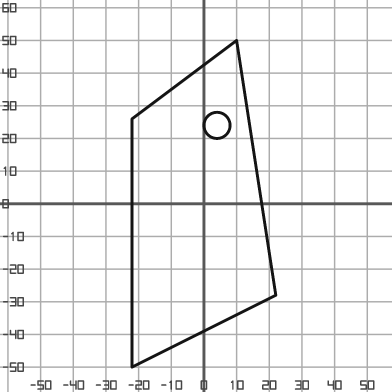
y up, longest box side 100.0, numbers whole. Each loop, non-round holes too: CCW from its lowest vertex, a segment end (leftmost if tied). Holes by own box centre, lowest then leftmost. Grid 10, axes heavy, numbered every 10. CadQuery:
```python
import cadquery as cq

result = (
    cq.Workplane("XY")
    .moveTo(-22.0, -50.0)
    .lineTo(22.0, -28.0)
    .lineTo(10.0, 50.0)
    .lineTo(-22.0, 26.0)
    .close()
    .moveTo(4.0, 24.0)
    .circle(4.0)
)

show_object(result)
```